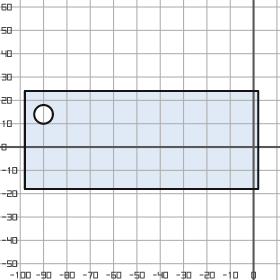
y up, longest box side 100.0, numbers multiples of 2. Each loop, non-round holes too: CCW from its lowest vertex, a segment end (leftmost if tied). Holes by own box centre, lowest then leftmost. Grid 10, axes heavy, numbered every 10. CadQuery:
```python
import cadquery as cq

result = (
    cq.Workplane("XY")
    .moveTo(-98.0, -18.0)
    .lineTo(2.0, -18.0)
    .lineTo(2.0, 24.0)
    .lineTo(-98.0, 24.0)
    .close()
    .moveTo(-90.0, 14.0)
    .circle(4.0)
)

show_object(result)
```